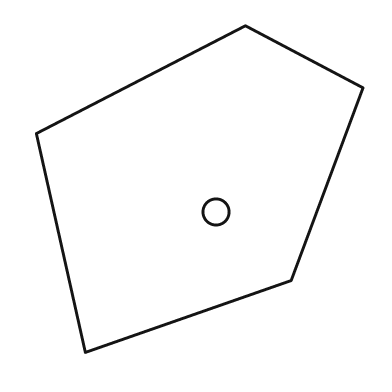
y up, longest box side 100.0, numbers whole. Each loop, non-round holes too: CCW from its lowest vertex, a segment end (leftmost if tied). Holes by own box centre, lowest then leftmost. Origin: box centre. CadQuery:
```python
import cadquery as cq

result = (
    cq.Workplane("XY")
    .moveTo(-35.0, -50.0)
    .lineTo(28.0, -28.0)
    .lineTo(50.0, 31.0)
    .lineTo(14.0, 50.0)
    .lineTo(-50.0, 17.0)
    .close()
    .moveTo(5.0, -7.0)
    .circle(4.0)
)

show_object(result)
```